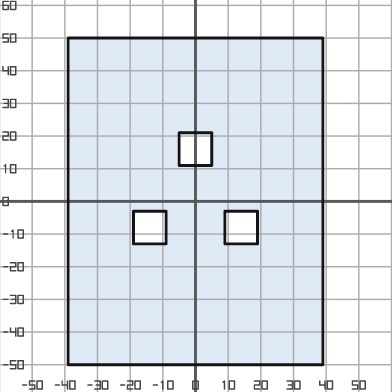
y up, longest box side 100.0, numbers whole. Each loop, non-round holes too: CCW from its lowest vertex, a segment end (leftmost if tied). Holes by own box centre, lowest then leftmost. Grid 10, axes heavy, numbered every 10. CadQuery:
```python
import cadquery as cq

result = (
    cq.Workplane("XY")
    .moveTo(-39.0, -50.0)
    .lineTo(39.0, -50.0)
    .lineTo(39.0, 50.0)
    .lineTo(-39.0, 50.0)
    .close()
    .moveTo(-19.0, -13.0)
    .lineTo(-9.0, -13.0)
    .lineTo(-9.0, -3.0)
    .lineTo(-19.0, -3.0)
    .close()
    .moveTo(9.0, -13.0)
    .lineTo(19.0, -13.0)
    .lineTo(19.0, -3.0)
    .lineTo(9.0, -3.0)
    .close()
    .moveTo(-5.0, 11.0)
    .lineTo(5.0, 11.0)
    .lineTo(5.0, 21.0)
    .lineTo(-5.0, 21.0)
    .close()
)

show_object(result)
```